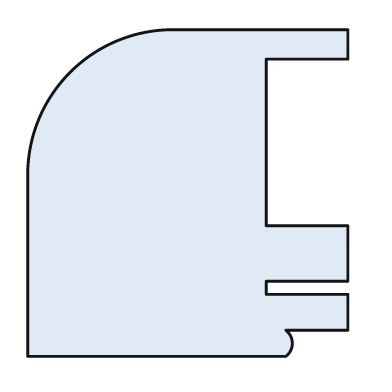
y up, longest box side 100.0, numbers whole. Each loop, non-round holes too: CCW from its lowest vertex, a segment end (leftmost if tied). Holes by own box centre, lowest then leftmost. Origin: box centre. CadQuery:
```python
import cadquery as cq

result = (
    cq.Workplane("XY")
    .moveTo(-49.0, -50.0)
    .lineTo(30.0, -50.0)
    .threePointArc((32.0, -46.0), (30.0, -42.0))
    .lineTo(49.0, -42.0)
    .lineTo(49.0, -31.0)
    .lineTo(24.0, -31.0)
    .lineTo(24.0, -27.0)
    .lineTo(49.0, -27.0)
    .lineTo(49.0, -10.0)
    .lineTo(24.0, -10.0)
    .lineTo(24.0, 41.0)
    .lineTo(49.0, 41.0)
    .lineTo(49.0, 50.0)
    .lineTo(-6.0, 50.0)
    .threePointArc((-36.0, 37.0), (-49.0, 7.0))
    .close()
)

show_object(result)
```